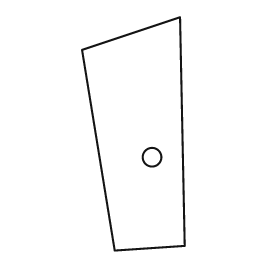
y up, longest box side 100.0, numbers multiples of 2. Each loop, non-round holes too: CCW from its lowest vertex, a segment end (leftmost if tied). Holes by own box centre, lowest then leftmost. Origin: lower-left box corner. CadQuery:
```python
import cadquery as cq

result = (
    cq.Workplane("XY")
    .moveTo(14.0, 0.0)
    .lineTo(44.0, 2.0)
    .lineTo(42.0, 100.0)
    .lineTo(0.0, 86.0)
    .close()
    .moveTo(30.0, 40.0)
    .circle(4.0)
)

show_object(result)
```